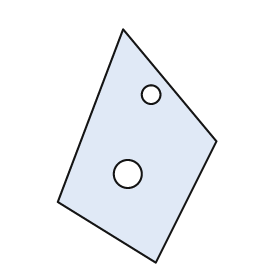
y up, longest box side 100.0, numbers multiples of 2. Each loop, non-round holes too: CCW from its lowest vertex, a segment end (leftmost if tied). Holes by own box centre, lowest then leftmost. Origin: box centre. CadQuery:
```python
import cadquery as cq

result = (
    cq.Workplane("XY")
    .moveTo(8.0, -50.0)
    .lineTo(34.0, 2.0)
    .lineTo(-6.0, 50.0)
    .lineTo(-34.0, -24.0)
    .close()
    .moveTo(-4.0, -12.0)
    .circle(6.0)
    .moveTo(6.0, 22.0)
    .circle(4.0)
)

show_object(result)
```